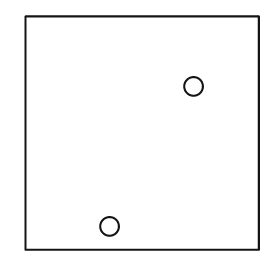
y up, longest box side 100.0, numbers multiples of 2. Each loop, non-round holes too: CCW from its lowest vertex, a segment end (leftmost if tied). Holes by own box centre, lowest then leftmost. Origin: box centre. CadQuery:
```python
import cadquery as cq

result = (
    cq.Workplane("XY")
    .moveTo(-50.0, -50.0)
    .lineTo(50.0, -50.0)
    .lineTo(50.0, 50.0)
    .lineTo(-50.0, 50.0)
    .close()
    .moveTo(-14.0, -40.0)
    .circle(4.0)
    .moveTo(22.0, 20.0)
    .circle(4.0)
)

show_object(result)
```